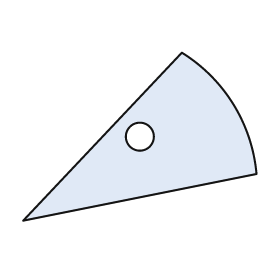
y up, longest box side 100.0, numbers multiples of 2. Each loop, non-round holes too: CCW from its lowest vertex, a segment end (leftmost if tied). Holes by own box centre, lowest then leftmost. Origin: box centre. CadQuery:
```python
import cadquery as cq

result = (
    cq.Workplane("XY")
    .moveTo(-50.0, -36.0)
    .lineTo(50.0, -16.0)
    .threePointArc((40.0, 14.0), (18.0, 36.0))
    .close()
    .moveTo(0.0, 0.0)
    .circle(6.0)
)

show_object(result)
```